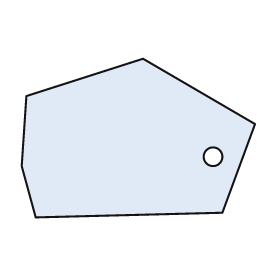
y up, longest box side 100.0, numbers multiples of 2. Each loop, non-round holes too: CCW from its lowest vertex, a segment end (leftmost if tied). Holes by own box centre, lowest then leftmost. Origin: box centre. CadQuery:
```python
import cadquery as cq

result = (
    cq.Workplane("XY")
    .moveTo(-44.0, -34.0)
    .lineTo(36.0, -32.0)
    .lineTo(50.0, 6.0)
    .lineTo(2.0, 34.0)
    .lineTo(-48.0, 18.0)
    .lineTo(-50.0, -12.0)
    .close()
    .moveTo(32.0, -8.0)
    .circle(4.0)
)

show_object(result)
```